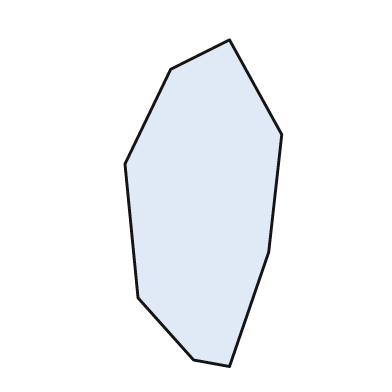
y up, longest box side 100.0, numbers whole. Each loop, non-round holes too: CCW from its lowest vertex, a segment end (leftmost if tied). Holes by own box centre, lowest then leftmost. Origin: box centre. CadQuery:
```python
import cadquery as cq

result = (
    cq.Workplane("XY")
    .moveTo(8.0, -50.0)
    .lineTo(20.0, -15.0)
    .lineTo(24.0, 21.0)
    .lineTo(8.0, 50.0)
    .lineTo(-10.0, 41.0)
    .lineTo(-24.0, 12.0)
    .lineTo(-20.0, -29.0)
    .lineTo(-3.0, -48.0)
    .close()
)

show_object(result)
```